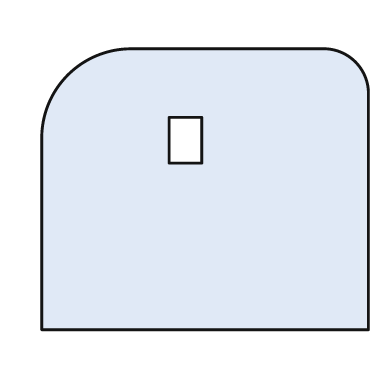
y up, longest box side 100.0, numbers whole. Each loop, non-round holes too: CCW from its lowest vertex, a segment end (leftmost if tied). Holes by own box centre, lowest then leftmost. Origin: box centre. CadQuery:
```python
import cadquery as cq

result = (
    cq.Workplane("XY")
    .moveTo(-50.0, -43.0)
    .lineTo(50.0, -43.0)
    .lineTo(50.0, 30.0)
    .threePointArc((46.0, 39.0), (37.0, 43.0))
    .lineTo(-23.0, 43.0)
    .threePointArc((-42.0, 35.0), (-50.0, 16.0))
    .close()
    .moveTo(-11.0, 8.0)
    .lineTo(-1.0, 8.0)
    .lineTo(-1.0, 22.0)
    .lineTo(-11.0, 22.0)
    .close()
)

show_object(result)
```